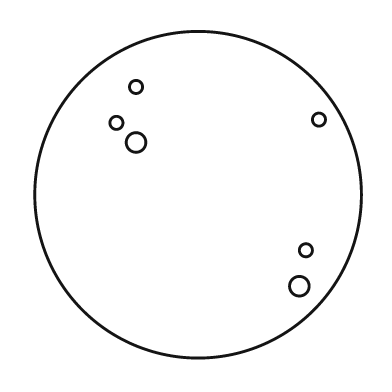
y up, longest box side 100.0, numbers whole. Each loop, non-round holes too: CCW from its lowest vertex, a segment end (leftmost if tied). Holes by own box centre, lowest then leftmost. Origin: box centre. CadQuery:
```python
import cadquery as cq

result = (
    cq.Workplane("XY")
    .moveTo(0.0, 0.0)
    .circle(50.0)
    .moveTo(31.0, -28.0)
    .circle(3.0)
    .moveTo(33.0, -17.0)
    .circle(2.0)
    .moveTo(-19.0, 16.0)
    .circle(3.0)
    .moveTo(-25.0, 22.0)
    .circle(2.0)
    .moveTo(37.0, 23.0)
    .circle(2.0)
    .moveTo(-19.0, 33.0)
    .circle(2.0)
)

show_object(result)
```